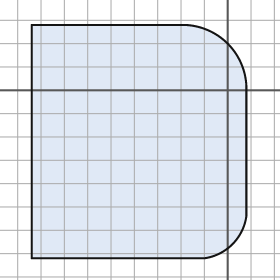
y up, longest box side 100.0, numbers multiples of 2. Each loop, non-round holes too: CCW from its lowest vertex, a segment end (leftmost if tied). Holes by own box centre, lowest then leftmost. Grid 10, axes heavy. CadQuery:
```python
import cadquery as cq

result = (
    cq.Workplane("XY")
    .moveTo(-84.0, -72.0)
    .lineTo(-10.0, -72.0)
    .threePointArc((2.0, -66.0), (8.0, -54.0))
    .lineTo(8.0, 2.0)
    .threePointArc((0.0, 20.0), (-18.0, 28.0))
    .lineTo(-84.0, 28.0)
    .close()
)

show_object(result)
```